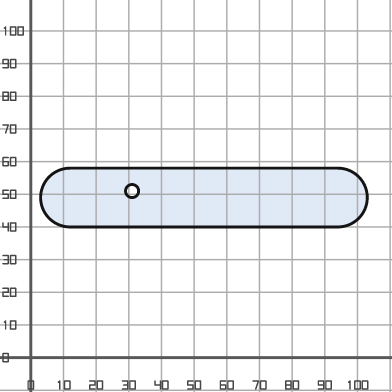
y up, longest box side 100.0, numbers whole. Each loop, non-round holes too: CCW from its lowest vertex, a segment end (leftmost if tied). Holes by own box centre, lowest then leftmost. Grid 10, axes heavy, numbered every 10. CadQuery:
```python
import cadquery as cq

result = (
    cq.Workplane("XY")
    .moveTo(12.0, 40.0)
    .lineTo(94.0, 40.0)
    .threePointArc((103.0, 49.0), (94.0, 58.0))
    .lineTo(12.0, 58.0)
    .threePointArc((3.0, 49.0), (12.0, 40.0))
    .close()
    .moveTo(31.0, 51.0)
    .circle(2.0)
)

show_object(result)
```